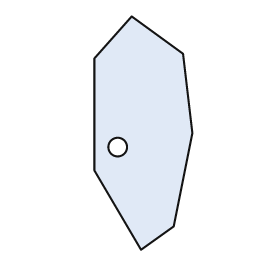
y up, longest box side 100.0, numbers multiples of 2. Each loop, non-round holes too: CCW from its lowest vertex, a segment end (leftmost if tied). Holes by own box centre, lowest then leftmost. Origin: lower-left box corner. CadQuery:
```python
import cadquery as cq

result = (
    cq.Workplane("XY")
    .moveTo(20.0, 0.0)
    .lineTo(34.0, 10.0)
    .lineTo(42.0, 50.0)
    .lineTo(38.0, 84.0)
    .lineTo(16.0, 100.0)
    .lineTo(0.0, 82.0)
    .lineTo(0.0, 34.0)
    .close()
    .moveTo(10.0, 44.0)
    .circle(4.0)
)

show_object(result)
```